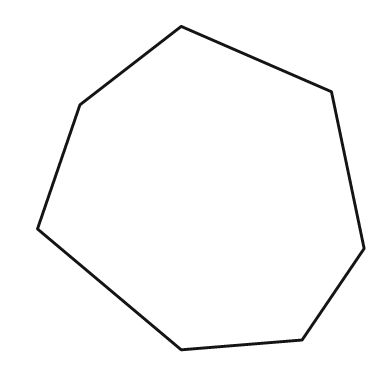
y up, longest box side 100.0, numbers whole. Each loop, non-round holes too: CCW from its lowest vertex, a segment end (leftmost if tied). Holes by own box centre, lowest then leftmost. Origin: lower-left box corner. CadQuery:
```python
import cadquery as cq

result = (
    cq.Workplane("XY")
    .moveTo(44.0, 0.0)
    .lineTo(81.0, 3.0)
    .lineTo(100.0, 31.0)
    .lineTo(90.0, 79.0)
    .lineTo(44.0, 99.0)
    .lineTo(13.0, 75.0)
    .lineTo(0.0, 37.0)
    .close()
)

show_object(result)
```